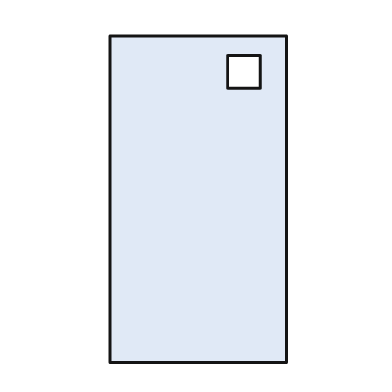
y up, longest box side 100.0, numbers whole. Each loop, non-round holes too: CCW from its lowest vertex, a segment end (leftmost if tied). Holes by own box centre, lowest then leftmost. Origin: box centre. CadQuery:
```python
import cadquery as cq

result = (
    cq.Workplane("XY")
    .moveTo(-27.0, -50.0)
    .lineTo(27.0, -50.0)
    .lineTo(27.0, 50.0)
    .lineTo(-27.0, 50.0)
    .close()
    .moveTo(9.0, 34.0)
    .lineTo(19.0, 34.0)
    .lineTo(19.0, 44.0)
    .lineTo(9.0, 44.0)
    .close()
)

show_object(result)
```